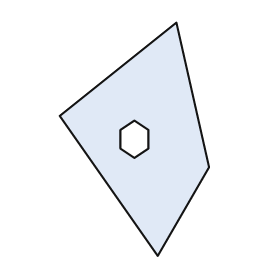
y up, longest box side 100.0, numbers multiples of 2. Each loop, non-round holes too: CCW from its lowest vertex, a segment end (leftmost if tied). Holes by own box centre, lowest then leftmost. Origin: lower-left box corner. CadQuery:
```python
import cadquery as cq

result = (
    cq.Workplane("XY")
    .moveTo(42.0, 0.0)
    .lineTo(64.0, 38.0)
    .lineTo(50.0, 100.0)
    .lineTo(0.0, 60.0)
    .close()
    .moveTo(32.0, 42.0)
    .lineTo(38.0, 46.0)
    .lineTo(38.0, 54.0)
    .lineTo(32.0, 58.0)
    .lineTo(26.0, 54.0)
    .lineTo(26.0, 46.0)
    .close()
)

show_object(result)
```